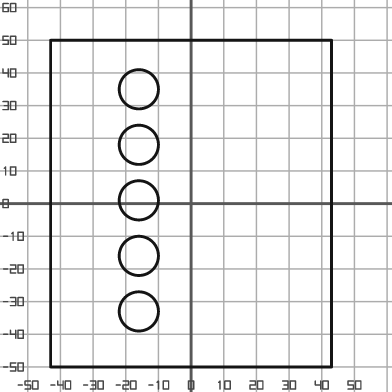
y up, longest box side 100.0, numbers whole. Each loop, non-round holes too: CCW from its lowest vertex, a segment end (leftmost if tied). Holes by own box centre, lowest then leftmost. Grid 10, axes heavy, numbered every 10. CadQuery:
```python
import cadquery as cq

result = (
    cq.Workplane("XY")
    .moveTo(-43.0, -50.0)
    .lineTo(43.0, -50.0)
    .lineTo(43.0, 50.0)
    .lineTo(-43.0, 50.0)
    .close()
    .moveTo(-16.0, -33.0)
    .circle(6.0)
    .moveTo(-16.0, -16.0)
    .circle(6.0)
    .moveTo(-16.0, 1.0)
    .circle(6.0)
    .moveTo(-16.0, 18.0)
    .circle(6.0)
    .moveTo(-16.0, 35.0)
    .circle(6.0)
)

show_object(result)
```